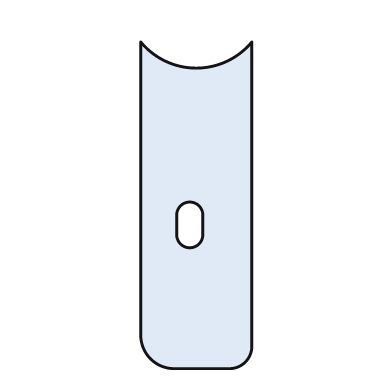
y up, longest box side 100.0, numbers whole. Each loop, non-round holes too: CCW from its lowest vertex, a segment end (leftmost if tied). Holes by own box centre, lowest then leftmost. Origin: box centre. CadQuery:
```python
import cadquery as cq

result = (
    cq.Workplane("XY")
    .moveTo(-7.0, -50.0)
    .lineTo(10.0, -50.0)
    .threePointArc((15.0, -48.0), (17.0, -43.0))
    .lineTo(17.0, 50.0)
    .threePointArc((0.0, 42.0), (-17.0, 50.0))
    .lineTo(-17.0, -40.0)
    .threePointArc((-14.0, -47.0), (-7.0, -50.0))
    .close()
    .moveTo(-6.0, -9.0)
    .threePointArc((-2.0, -13.0), (2.0, -9.0))
    .lineTo(2.0, -3.0)
    .threePointArc((-2.0, 1.0), (-6.0, -3.0))
    .close()
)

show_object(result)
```